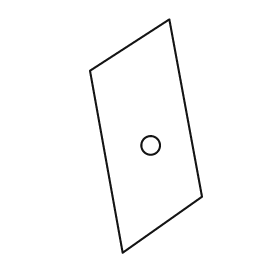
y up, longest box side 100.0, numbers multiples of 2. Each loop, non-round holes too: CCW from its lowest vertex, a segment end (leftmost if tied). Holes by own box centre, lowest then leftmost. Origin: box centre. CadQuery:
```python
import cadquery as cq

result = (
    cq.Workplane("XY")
    .moveTo(-10.0, -50.0)
    .lineTo(24.0, -26.0)
    .lineTo(10.0, 50.0)
    .lineTo(-24.0, 28.0)
    .close()
    .moveTo(2.0, -4.0)
    .circle(4.0)
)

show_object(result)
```